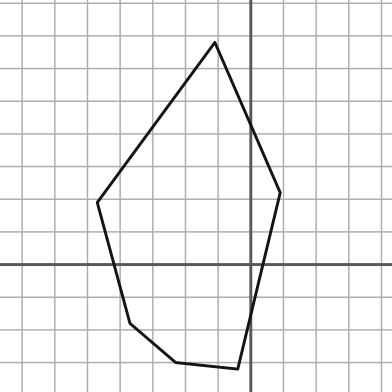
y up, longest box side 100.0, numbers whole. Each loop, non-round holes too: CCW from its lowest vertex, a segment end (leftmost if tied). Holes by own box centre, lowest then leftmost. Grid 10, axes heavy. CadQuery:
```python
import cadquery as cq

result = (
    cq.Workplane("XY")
    .moveTo(-4.0, -32.0)
    .lineTo(9.0, 22.0)
    .lineTo(-11.0, 68.0)
    .lineTo(-47.0, 19.0)
    .lineTo(-37.0, -18.0)
    .lineTo(-23.0, -30.0)
    .close()
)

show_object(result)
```